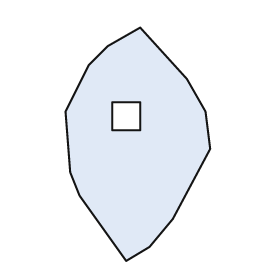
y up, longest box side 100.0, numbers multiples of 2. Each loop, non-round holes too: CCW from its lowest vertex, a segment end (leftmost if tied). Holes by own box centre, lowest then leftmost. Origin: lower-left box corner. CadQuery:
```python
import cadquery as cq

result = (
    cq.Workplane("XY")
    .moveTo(26.0, 0.0)
    .lineTo(36.0, 6.0)
    .lineTo(46.0, 18.0)
    .lineTo(62.0, 48.0)
    .lineTo(60.0, 64.0)
    .lineTo(52.0, 78.0)
    .lineTo(32.0, 100.0)
    .lineTo(18.0, 92.0)
    .lineTo(10.0, 84.0)
    .lineTo(0.0, 64.0)
    .lineTo(2.0, 38.0)
    .lineTo(6.0, 28.0)
    .close()
    .moveTo(20.0, 56.0)
    .lineTo(32.0, 56.0)
    .lineTo(32.0, 68.0)
    .lineTo(20.0, 68.0)
    .close()
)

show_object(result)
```